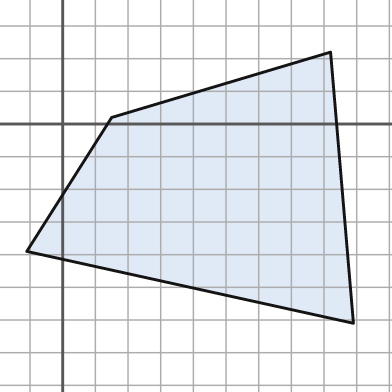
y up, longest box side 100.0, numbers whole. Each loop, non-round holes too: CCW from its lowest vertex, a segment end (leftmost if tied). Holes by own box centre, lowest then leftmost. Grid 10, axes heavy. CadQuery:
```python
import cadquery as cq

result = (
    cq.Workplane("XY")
    .moveTo(89.0, -61.0)
    .lineTo(82.0, 22.0)
    .lineTo(15.0, 2.0)
    .lineTo(-11.0, -39.0)
    .close()
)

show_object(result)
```